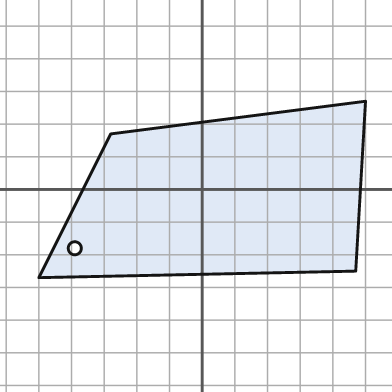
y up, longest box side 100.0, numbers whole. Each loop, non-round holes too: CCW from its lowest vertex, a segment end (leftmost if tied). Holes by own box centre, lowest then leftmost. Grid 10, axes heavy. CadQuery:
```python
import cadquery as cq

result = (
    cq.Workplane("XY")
    .moveTo(-50.0, -27.0)
    .lineTo(47.0, -25.0)
    .lineTo(50.0, 27.0)
    .lineTo(-28.0, 17.0)
    .close()
    .moveTo(-39.0, -18.0)
    .circle(2.0)
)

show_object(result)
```